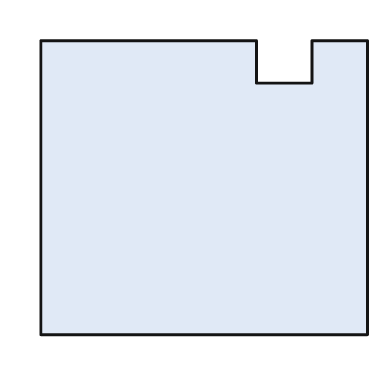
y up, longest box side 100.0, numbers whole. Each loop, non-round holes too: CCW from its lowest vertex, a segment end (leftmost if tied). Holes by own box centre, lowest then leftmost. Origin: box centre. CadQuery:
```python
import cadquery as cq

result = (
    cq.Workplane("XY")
    .moveTo(-50.0, -45.0)
    .lineTo(50.0, -45.0)
    .lineTo(50.0, 45.0)
    .lineTo(33.0, 45.0)
    .lineTo(33.0, 32.0)
    .lineTo(16.0, 32.0)
    .lineTo(16.0, 45.0)
    .lineTo(-50.0, 45.0)
    .close()
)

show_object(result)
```